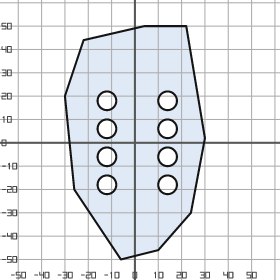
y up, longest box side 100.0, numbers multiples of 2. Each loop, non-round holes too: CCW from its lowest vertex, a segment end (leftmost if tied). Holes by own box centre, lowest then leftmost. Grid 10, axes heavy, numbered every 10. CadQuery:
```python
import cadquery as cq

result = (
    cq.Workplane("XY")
    .moveTo(-6.0, -50.0)
    .lineTo(10.0, -46.0)
    .lineTo(24.0, -30.0)
    .lineTo(30.0, 2.0)
    .lineTo(22.0, 50.0)
    .lineTo(4.0, 50.0)
    .lineTo(-22.0, 44.0)
    .lineTo(-30.0, 20.0)
    .lineTo(-26.0, -20.0)
    .close()
    .moveTo(-12.0, -18.0)
    .circle(4.0)
    .moveTo(14.0, -18.0)
    .circle(4.0)
    .moveTo(-12.0, -6.0)
    .circle(4.0)
    .moveTo(14.0, -6.0)
    .circle(4.0)
    .moveTo(-12.0, 6.0)
    .circle(4.0)
    .moveTo(14.0, 6.0)
    .circle(4.0)
    .moveTo(-12.0, 18.0)
    .circle(4.0)
    .moveTo(14.0, 18.0)
    .circle(4.0)
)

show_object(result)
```